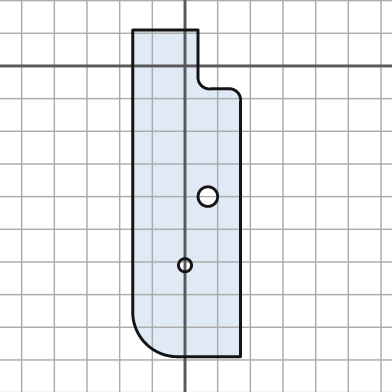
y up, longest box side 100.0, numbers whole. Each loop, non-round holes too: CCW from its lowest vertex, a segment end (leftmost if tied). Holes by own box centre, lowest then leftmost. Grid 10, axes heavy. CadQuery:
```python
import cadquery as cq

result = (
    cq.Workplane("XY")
    .moveTo(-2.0, -89.0)
    .lineTo(17.0, -89.0)
    .lineTo(17.0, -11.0)
    .threePointArc((16.0, -8.0), (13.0, -7.0))
    .lineTo(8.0, -7.0)
    .threePointArc((5.0, -6.0), (4.0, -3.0))
    .lineTo(4.0, 11.0)
    .lineTo(-16.0, 11.0)
    .lineTo(-16.0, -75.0)
    .threePointArc((-12.0, -85.0), (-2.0, -89.0))
    .close()
    .moveTo(0.0, -61.0)
    .circle(2.0)
    .moveTo(7.0, -40.0)
    .circle(3.0)
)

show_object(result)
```